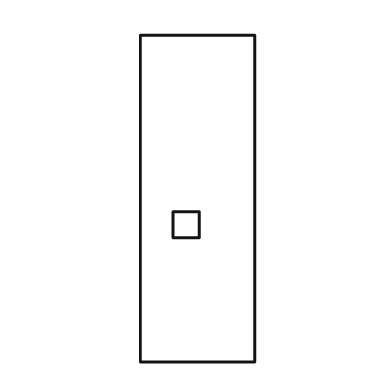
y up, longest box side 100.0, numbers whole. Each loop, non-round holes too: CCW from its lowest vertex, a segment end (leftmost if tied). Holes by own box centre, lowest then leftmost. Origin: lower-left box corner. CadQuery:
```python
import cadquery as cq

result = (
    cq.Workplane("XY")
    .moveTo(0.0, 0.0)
    .lineTo(35.0, 0.0)
    .lineTo(35.0, 100.0)
    .lineTo(0.0, 100.0)
    .close()
    .moveTo(10.0, 38.0)
    .lineTo(18.0, 38.0)
    .lineTo(18.0, 46.0)
    .lineTo(10.0, 46.0)
    .close()
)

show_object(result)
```